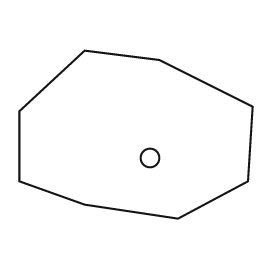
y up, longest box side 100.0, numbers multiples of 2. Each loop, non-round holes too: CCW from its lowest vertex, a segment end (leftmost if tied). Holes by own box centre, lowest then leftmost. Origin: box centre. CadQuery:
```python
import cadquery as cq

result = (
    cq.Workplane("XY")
    .moveTo(18.0, -36.0)
    .lineTo(48.0, -20.0)
    .lineTo(50.0, 12.0)
    .lineTo(10.0, 32.0)
    .lineTo(-22.0, 36.0)
    .lineTo(-50.0, 10.0)
    .lineTo(-50.0, -20.0)
    .lineTo(-22.0, -30.0)
    .close()
    .moveTo(6.0, -10.0)
    .circle(4.0)
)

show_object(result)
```